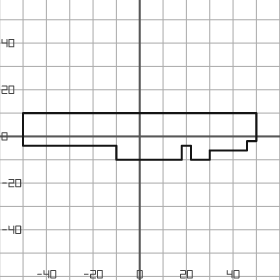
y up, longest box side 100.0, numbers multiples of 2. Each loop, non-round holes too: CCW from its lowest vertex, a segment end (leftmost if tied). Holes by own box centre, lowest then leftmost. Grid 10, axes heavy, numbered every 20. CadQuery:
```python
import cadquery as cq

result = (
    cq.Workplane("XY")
    .moveTo(-10.0, -10.0)
    .lineTo(18.0, -10.0)
    .lineTo(18.0, -4.0)
    .lineTo(22.0, -4.0)
    .lineTo(22.0, -10.0)
    .lineTo(30.0, -10.0)
    .lineTo(30.0, -6.0)
    .lineTo(46.0, -6.0)
    .lineTo(46.0, -2.0)
    .lineTo(50.0, -2.0)
    .lineTo(50.0, 10.0)
    .lineTo(-50.0, 10.0)
    .lineTo(-50.0, -4.0)
    .lineTo(-10.0, -4.0)
    .close()
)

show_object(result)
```